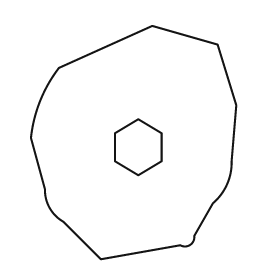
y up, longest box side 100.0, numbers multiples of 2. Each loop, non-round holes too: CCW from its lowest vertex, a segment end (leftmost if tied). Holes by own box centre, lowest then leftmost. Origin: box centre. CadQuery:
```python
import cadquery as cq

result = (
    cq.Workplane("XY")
    .moveTo(-14.0, -50.0)
    .lineTo(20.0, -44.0)
    .threePointArc((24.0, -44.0), (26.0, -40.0))
    .lineTo(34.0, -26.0)
    .threePointArc((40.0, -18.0), (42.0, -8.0))
    .lineTo(44.0, 16.0)
    .lineTo(36.0, 42.0)
    .lineTo(8.0, 50.0)
    .lineTo(-32.0, 32.0)
    .threePointArc((-40.0, 18.0), (-44.0, 2.0))
    .lineTo(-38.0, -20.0)
    .threePointArc((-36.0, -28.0), (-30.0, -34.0))
    .close()
    .moveTo(2.0, -14.0)
    .lineTo(12.0, -8.0)
    .lineTo(12.0, 4.0)
    .lineTo(2.0, 10.0)
    .lineTo(-8.0, 4.0)
    .lineTo(-8.0, -8.0)
    .close()
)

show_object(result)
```